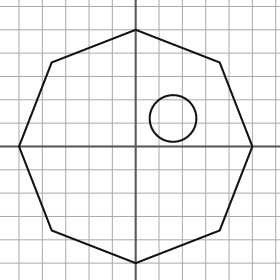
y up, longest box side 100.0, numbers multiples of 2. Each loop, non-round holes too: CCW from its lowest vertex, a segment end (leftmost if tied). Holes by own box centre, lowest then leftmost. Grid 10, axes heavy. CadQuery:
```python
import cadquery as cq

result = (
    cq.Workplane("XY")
    .moveTo(0.0, -50.0)
    .lineTo(36.0, -36.0)
    .lineTo(50.0, 0.0)
    .lineTo(36.0, 36.0)
    .lineTo(0.0, 50.0)
    .lineTo(-36.0, 36.0)
    .lineTo(-50.0, 0.0)
    .lineTo(-36.0, -36.0)
    .close()
    .moveTo(16.0, 12.0)
    .circle(10.0)
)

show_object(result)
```